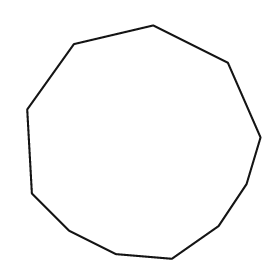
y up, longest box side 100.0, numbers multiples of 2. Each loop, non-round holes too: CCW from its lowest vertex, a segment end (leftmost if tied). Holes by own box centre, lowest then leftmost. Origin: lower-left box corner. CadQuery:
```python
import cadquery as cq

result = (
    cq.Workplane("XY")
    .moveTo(62.0, 0.0)
    .lineTo(82.0, 14.0)
    .lineTo(94.0, 32.0)
    .lineTo(100.0, 52.0)
    .lineTo(86.0, 84.0)
    .lineTo(54.0, 100.0)
    .lineTo(20.0, 92.0)
    .lineTo(0.0, 64.0)
    .lineTo(2.0, 28.0)
    .lineTo(18.0, 12.0)
    .lineTo(38.0, 2.0)
    .close()
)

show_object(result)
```